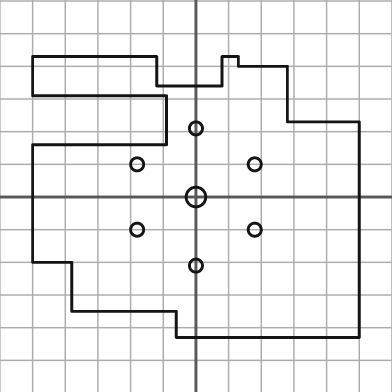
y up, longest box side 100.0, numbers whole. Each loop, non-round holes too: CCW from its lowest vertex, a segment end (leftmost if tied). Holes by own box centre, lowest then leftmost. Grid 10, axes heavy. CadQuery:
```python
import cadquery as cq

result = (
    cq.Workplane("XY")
    .moveTo(-6.0, -43.0)
    .lineTo(50.0, -43.0)
    .lineTo(50.0, 23.0)
    .lineTo(28.0, 23.0)
    .lineTo(28.0, 40.0)
    .lineTo(13.0, 40.0)
    .lineTo(13.0, 43.0)
    .lineTo(8.0, 43.0)
    .lineTo(8.0, 34.0)
    .lineTo(-12.0, 34.0)
    .lineTo(-12.0, 43.0)
    .lineTo(-50.0, 43.0)
    .lineTo(-50.0, 31.0)
    .lineTo(-9.0, 31.0)
    .lineTo(-9.0, 16.0)
    .lineTo(-50.0, 16.0)
    .lineTo(-50.0, -20.0)
    .lineTo(-38.0, -20.0)
    .lineTo(-38.0, -35.0)
    .lineTo(-6.0, -35.0)
    .close()
    .moveTo(0.0, -21.0)
    .circle(2.0)
    .moveTo(-18.0, -10.0)
    .circle(2.0)
    .moveTo(18.0, -10.0)
    .circle(2.0)
    .moveTo(0.0, 0.0)
    .circle(3.0)
    .moveTo(-18.0, 10.0)
    .circle(2.0)
    .moveTo(18.0, 10.0)
    .circle(2.0)
    .moveTo(0.0, 21.0)
    .circle(2.0)
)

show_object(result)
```